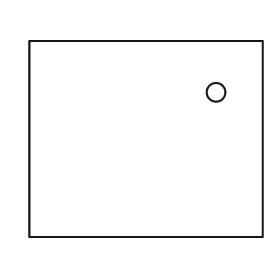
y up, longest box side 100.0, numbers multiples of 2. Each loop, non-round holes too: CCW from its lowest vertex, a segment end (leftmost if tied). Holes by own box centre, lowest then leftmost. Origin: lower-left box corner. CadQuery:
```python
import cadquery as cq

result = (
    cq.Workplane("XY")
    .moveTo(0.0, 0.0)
    .lineTo(100.0, 0.0)
    .lineTo(100.0, 84.0)
    .lineTo(0.0, 84.0)
    .close()
    .moveTo(80.0, 62.0)
    .circle(4.0)
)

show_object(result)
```